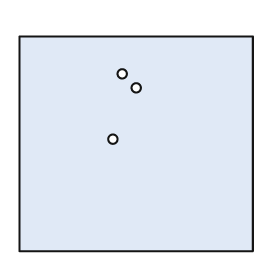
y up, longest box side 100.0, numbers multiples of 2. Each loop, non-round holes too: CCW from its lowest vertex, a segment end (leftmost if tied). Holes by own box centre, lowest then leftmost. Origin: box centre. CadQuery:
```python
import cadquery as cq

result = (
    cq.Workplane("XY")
    .moveTo(-50.0, -46.0)
    .lineTo(50.0, -46.0)
    .lineTo(50.0, 46.0)
    .lineTo(-50.0, 46.0)
    .close()
    .moveTo(-10.0, 2.0)
    .circle(2.0)
    .moveTo(0.0, 24.0)
    .circle(2.0)
    .moveTo(-6.0, 30.0)
    .circle(2.0)
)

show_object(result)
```